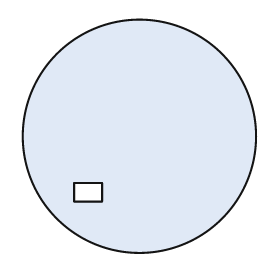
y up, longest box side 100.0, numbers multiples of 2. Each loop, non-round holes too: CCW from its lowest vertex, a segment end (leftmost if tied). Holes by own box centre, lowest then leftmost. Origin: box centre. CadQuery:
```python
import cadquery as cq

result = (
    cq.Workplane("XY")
    .moveTo(0.0, 0.0)
    .circle(50.0)
    .moveTo(-28.0, -28.0)
    .lineTo(-16.0, -28.0)
    .lineTo(-16.0, -20.0)
    .lineTo(-28.0, -20.0)
    .close()
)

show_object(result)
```